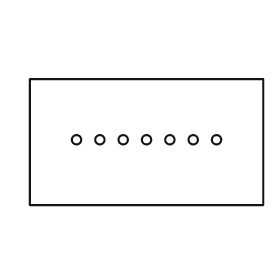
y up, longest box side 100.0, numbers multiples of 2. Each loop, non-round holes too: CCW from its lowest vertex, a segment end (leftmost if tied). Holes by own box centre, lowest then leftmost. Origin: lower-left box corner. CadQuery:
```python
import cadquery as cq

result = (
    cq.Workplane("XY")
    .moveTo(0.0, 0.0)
    .lineTo(100.0, 0.0)
    .lineTo(100.0, 54.0)
    .lineTo(0.0, 54.0)
    .close()
    .moveTo(20.0, 28.0)
    .circle(2.0)
    .moveTo(30.0, 28.0)
    .circle(2.0)
    .moveTo(40.0, 28.0)
    .circle(2.0)
    .moveTo(50.0, 28.0)
    .circle(2.0)
    .moveTo(60.0, 28.0)
    .circle(2.0)
    .moveTo(70.0, 28.0)
    .circle(2.0)
    .moveTo(80.0, 28.0)
    .circle(2.0)
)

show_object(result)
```